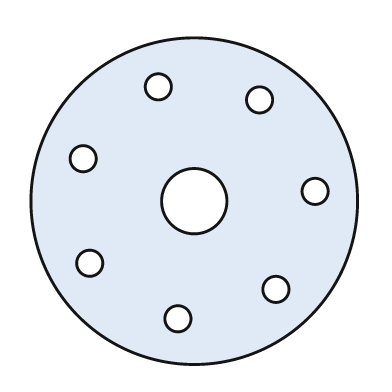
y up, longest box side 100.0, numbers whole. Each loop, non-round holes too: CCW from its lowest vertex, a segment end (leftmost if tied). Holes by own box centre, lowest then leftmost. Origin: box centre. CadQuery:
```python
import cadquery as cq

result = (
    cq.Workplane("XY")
    .moveTo(0.0, 0.0)
    .circle(50.0)
    .moveTo(-5.0, -36.0)
    .circle(4.0)
    .moveTo(25.0, -27.0)
    .circle(4.0)
    .moveTo(-32.0, -19.0)
    .circle(4.0)
    .moveTo(0.0, 0.0)
    .circle(10.0)
    .moveTo(37.0, 3.0)
    .circle(4.0)
    .moveTo(-34.0, 13.0)
    .circle(4.0)
    .moveTo(20.0, 31.0)
    .circle(4.0)
    .moveTo(-11.0, 35.0)
    .circle(4.0)
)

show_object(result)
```